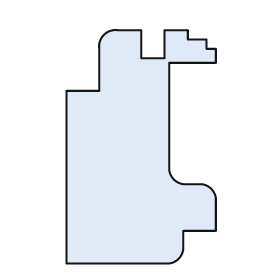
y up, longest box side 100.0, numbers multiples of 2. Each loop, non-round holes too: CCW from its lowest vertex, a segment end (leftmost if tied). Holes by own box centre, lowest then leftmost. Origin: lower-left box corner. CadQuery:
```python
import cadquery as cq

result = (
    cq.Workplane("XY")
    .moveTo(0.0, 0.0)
    .lineTo(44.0, 0.0)
    .threePointArc((48.0, 2.0), (50.0, 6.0))
    .lineTo(50.0, 14.0)
    .lineTo(64.0, 14.0)
    .lineTo(64.0, 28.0)
    .threePointArc((62.0, 32.0), (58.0, 34.0))
    .lineTo(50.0, 34.0)
    .threePointArc((46.0, 36.0), (44.0, 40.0))
    .lineTo(44.0, 86.0)
    .lineTo(64.0, 86.0)
    .lineTo(64.0, 92.0)
    .lineTo(60.0, 92.0)
    .lineTo(60.0, 96.0)
    .lineTo(52.0, 96.0)
    .lineTo(52.0, 100.0)
    .lineTo(42.0, 100.0)
    .lineTo(42.0, 88.0)
    .lineTo(32.0, 88.0)
    .lineTo(32.0, 100.0)
    .lineTo(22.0, 100.0)
    .threePointArc((16.0, 98.0), (14.0, 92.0))
    .lineTo(14.0, 74.0)
    .lineTo(0.0, 74.0)
    .close()
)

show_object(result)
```